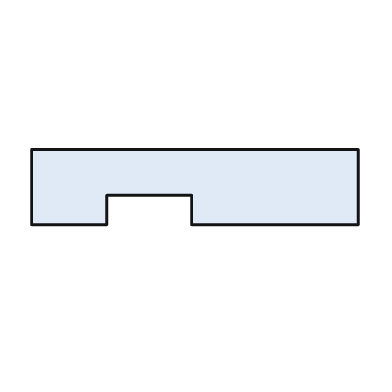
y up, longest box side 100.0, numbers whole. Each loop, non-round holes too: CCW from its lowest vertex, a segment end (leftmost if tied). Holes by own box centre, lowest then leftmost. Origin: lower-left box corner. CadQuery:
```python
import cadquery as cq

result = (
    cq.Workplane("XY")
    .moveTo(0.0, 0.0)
    .lineTo(23.0, 0.0)
    .lineTo(23.0, 9.0)
    .lineTo(49.0, 9.0)
    .lineTo(49.0, 0.0)
    .lineTo(100.0, 0.0)
    .lineTo(100.0, 23.0)
    .lineTo(0.0, 23.0)
    .close()
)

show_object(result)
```